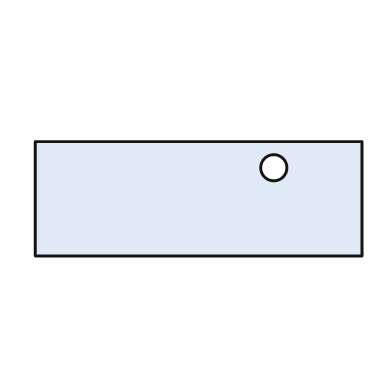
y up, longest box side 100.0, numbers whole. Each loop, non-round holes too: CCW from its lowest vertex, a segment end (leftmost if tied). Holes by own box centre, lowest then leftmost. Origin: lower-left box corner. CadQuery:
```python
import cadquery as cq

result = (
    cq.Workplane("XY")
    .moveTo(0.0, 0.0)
    .lineTo(100.0, 0.0)
    .lineTo(100.0, 35.0)
    .lineTo(0.0, 35.0)
    .close()
    .moveTo(73.0, 27.0)
    .circle(4.0)
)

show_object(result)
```